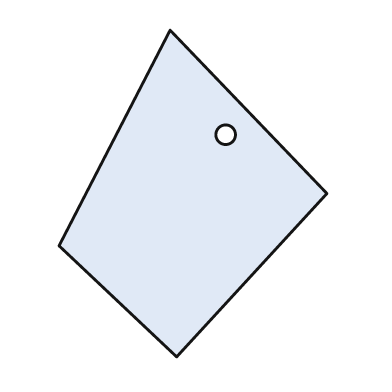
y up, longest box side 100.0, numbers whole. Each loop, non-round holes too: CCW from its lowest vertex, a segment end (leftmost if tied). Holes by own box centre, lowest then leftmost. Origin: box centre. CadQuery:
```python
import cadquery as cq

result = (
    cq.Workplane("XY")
    .moveTo(-5.0, -50.0)
    .lineTo(41.0, 0.0)
    .lineTo(-7.0, 50.0)
    .lineTo(-41.0, -16.0)
    .close()
    .moveTo(10.0, 18.0)
    .circle(3.0)
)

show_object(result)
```